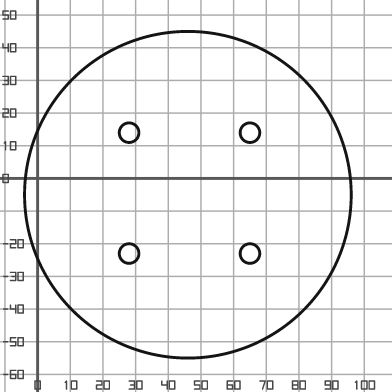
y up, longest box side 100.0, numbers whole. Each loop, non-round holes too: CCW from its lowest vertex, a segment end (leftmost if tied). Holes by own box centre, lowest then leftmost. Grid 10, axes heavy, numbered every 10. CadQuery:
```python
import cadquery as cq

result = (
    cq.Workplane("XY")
    .moveTo(46.0, -5.0)
    .circle(50.0)
    .moveTo(28.0, -23.0)
    .circle(3.0)
    .moveTo(65.0, -23.0)
    .circle(3.0)
    .moveTo(28.0, 14.0)
    .circle(3.0)
    .moveTo(65.0, 14.0)
    .circle(3.0)
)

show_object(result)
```